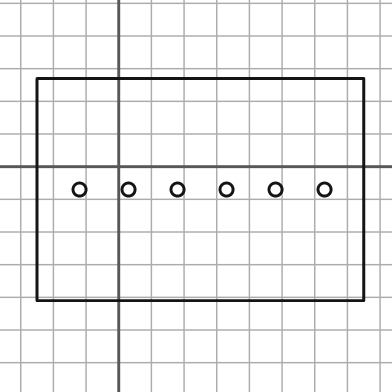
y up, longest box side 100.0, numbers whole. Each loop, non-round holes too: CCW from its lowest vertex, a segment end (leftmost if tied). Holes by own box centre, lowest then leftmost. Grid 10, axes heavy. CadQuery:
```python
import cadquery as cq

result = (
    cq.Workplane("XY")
    .moveTo(-25.0, -41.0)
    .lineTo(75.0, -41.0)
    .lineTo(75.0, 27.0)
    .lineTo(-25.0, 27.0)
    .close()
    .moveTo(-12.0, -7.0)
    .circle(2.0)
    .moveTo(3.0, -7.0)
    .circle(2.0)
    .moveTo(18.0, -7.0)
    .circle(2.0)
    .moveTo(33.0, -7.0)
    .circle(2.0)
    .moveTo(48.0, -7.0)
    .circle(2.0)
    .moveTo(63.0, -7.0)
    .circle(2.0)
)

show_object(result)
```